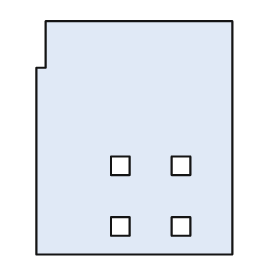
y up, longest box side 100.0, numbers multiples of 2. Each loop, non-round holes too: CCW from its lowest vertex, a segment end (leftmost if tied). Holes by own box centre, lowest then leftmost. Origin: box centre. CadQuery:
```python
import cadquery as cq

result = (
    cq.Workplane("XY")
    .moveTo(-42.0, -50.0)
    .lineTo(42.0, -50.0)
    .lineTo(42.0, 50.0)
    .lineTo(-38.0, 50.0)
    .lineTo(-38.0, 30.0)
    .lineTo(-42.0, 30.0)
    .close()
    .moveTo(-10.0, -42.0)
    .lineTo(-2.0, -42.0)
    .lineTo(-2.0, -34.0)
    .lineTo(-10.0, -34.0)
    .close()
    .moveTo(16.0, -42.0)
    .lineTo(24.0, -42.0)
    .lineTo(24.0, -34.0)
    .lineTo(16.0, -34.0)
    .close()
    .moveTo(-10.0, -16.0)
    .lineTo(-2.0, -16.0)
    .lineTo(-2.0, -8.0)
    .lineTo(-10.0, -8.0)
    .close()
    .moveTo(16.0, -16.0)
    .lineTo(24.0, -16.0)
    .lineTo(24.0, -8.0)
    .lineTo(16.0, -8.0)
    .close()
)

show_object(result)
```